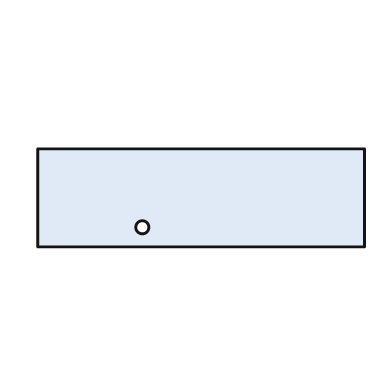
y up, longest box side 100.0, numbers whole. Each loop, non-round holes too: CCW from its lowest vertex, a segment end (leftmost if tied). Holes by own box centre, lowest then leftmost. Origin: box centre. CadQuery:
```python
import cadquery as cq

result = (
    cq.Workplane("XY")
    .moveTo(-50.0, -15.0)
    .lineTo(50.0, -15.0)
    .lineTo(50.0, 15.0)
    .lineTo(-50.0, 15.0)
    .close()
    .moveTo(-18.0, -9.0)
    .circle(2.0)
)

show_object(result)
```